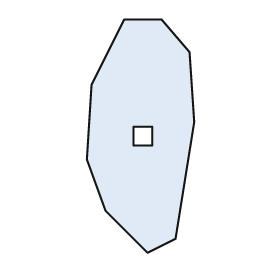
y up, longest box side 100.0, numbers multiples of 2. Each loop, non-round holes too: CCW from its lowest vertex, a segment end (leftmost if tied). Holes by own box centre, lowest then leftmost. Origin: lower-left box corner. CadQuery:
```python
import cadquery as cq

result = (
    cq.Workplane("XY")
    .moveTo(26.0, 0.0)
    .lineTo(38.0, 6.0)
    .lineTo(46.0, 56.0)
    .lineTo(44.0, 86.0)
    .lineTo(32.0, 100.0)
    .lineTo(16.0, 100.0)
    .lineTo(2.0, 72.0)
    .lineTo(0.0, 40.0)
    .lineTo(8.0, 18.0)
    .close()
    .moveTo(20.0, 46.0)
    .lineTo(28.0, 46.0)
    .lineTo(28.0, 54.0)
    .lineTo(20.0, 54.0)
    .close()
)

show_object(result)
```